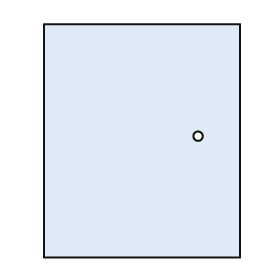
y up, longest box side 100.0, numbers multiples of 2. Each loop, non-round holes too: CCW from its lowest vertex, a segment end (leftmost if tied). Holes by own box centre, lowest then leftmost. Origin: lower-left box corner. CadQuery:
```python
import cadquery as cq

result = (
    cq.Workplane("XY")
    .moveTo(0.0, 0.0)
    .lineTo(84.0, 0.0)
    .lineTo(84.0, 100.0)
    .lineTo(0.0, 100.0)
    .close()
    .moveTo(66.0, 52.0)
    .circle(2.0)
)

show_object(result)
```